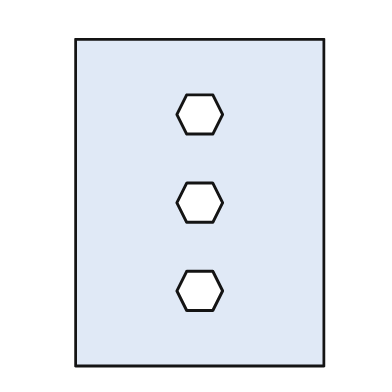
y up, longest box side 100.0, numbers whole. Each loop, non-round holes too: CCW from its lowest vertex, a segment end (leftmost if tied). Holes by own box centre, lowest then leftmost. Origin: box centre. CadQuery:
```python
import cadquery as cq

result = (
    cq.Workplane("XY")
    .moveTo(-38.0, -50.0)
    .lineTo(38.0, -50.0)
    .lineTo(38.0, 50.0)
    .lineTo(-38.0, 50.0)
    .close()
    .moveTo(-4.0, -33.0)
    .lineTo(4.0, -33.0)
    .lineTo(7.0, -27.0)
    .lineTo(4.0, -21.0)
    .lineTo(-4.0, -21.0)
    .lineTo(-7.0, -27.0)
    .close()
    .moveTo(-4.0, -6.0)
    .lineTo(4.0, -6.0)
    .lineTo(7.0, 0.0)
    .lineTo(4.0, 6.0)
    .lineTo(-4.0, 6.0)
    .lineTo(-7.0, 0.0)
    .close()
    .moveTo(-4.0, 21.0)
    .lineTo(4.0, 21.0)
    .lineTo(7.0, 27.0)
    .lineTo(4.0, 33.0)
    .lineTo(-4.0, 33.0)
    .lineTo(-7.0, 27.0)
    .close()
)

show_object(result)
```